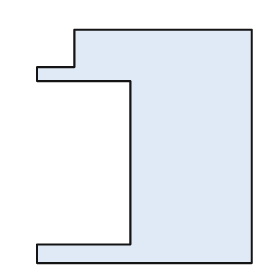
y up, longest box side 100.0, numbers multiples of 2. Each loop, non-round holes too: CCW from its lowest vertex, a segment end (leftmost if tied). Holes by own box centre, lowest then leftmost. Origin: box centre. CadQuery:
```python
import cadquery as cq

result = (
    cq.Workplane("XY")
    .moveTo(-46.0, -50.0)
    .lineTo(46.0, -50.0)
    .lineTo(46.0, 50.0)
    .lineTo(-30.0, 50.0)
    .lineTo(-30.0, 34.0)
    .lineTo(-46.0, 34.0)
    .lineTo(-46.0, 28.0)
    .lineTo(-6.0, 28.0)
    .lineTo(-6.0, -42.0)
    .lineTo(-46.0, -42.0)
    .close()
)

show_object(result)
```